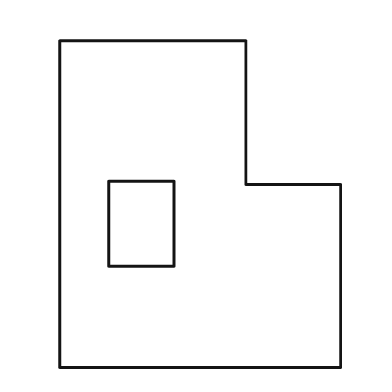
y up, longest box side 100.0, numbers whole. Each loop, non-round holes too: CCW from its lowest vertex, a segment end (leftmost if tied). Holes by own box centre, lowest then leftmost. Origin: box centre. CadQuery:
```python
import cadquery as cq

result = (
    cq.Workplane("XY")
    .moveTo(-43.0, -50.0)
    .lineTo(43.0, -50.0)
    .lineTo(43.0, 6.0)
    .lineTo(14.0, 6.0)
    .lineTo(14.0, 50.0)
    .lineTo(-43.0, 50.0)
    .close()
    .moveTo(-28.0, -19.0)
    .lineTo(-8.0, -19.0)
    .lineTo(-8.0, 7.0)
    .lineTo(-28.0, 7.0)
    .close()
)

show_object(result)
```